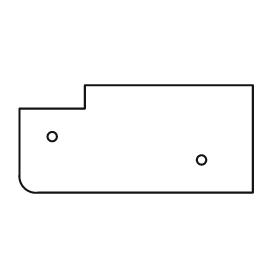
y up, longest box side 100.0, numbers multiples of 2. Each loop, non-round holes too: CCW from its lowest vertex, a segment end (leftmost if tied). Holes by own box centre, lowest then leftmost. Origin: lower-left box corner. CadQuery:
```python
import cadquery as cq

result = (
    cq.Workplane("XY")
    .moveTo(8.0, 0.0)
    .lineTo(100.0, 0.0)
    .lineTo(100.0, 46.0)
    .lineTo(28.0, 46.0)
    .lineTo(28.0, 36.0)
    .lineTo(0.0, 36.0)
    .lineTo(0.0, 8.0)
    .threePointArc((2.0, 2.0), (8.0, 0.0))
    .close()
    .moveTo(78.0, 14.0)
    .circle(2.0)
    .moveTo(14.0, 24.0)
    .circle(2.0)
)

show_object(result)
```